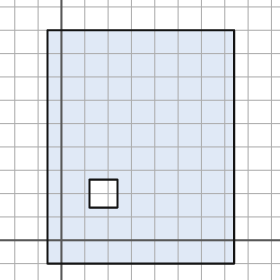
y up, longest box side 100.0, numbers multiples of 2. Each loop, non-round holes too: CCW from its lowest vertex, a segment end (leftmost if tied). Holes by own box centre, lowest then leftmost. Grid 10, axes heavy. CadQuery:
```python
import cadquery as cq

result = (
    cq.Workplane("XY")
    .moveTo(-6.0, -10.0)
    .lineTo(74.0, -10.0)
    .lineTo(74.0, 90.0)
    .lineTo(-6.0, 90.0)
    .close()
    .moveTo(12.0, 14.0)
    .lineTo(24.0, 14.0)
    .lineTo(24.0, 26.0)
    .lineTo(12.0, 26.0)
    .close()
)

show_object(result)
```